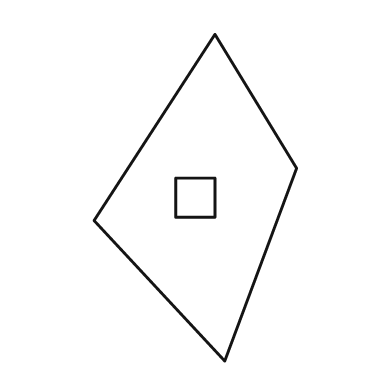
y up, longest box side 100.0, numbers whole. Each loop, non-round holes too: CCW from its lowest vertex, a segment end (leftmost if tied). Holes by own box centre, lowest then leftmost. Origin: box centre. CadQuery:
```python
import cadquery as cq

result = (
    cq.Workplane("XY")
    .moveTo(9.0, -50.0)
    .lineTo(31.0, 9.0)
    .lineTo(6.0, 50.0)
    .lineTo(-31.0, -7.0)
    .close()
    .moveTo(-6.0, -6.0)
    .lineTo(6.0, -6.0)
    .lineTo(6.0, 6.0)
    .lineTo(-6.0, 6.0)
    .close()
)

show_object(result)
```